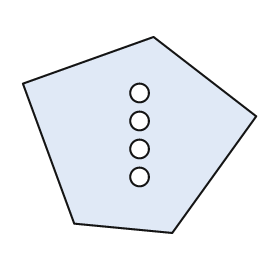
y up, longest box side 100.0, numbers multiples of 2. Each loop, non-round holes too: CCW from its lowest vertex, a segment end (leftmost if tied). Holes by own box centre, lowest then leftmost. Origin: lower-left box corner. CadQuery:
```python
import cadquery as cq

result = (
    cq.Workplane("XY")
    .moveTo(64.0, 0.0)
    .lineTo(100.0, 50.0)
    .lineTo(56.0, 84.0)
    .lineTo(0.0, 64.0)
    .lineTo(22.0, 4.0)
    .close()
    .moveTo(50.0, 24.0)
    .circle(4.0)
    .moveTo(50.0, 36.0)
    .circle(4.0)
    .moveTo(50.0, 48.0)
    .circle(4.0)
    .moveTo(50.0, 60.0)
    .circle(4.0)
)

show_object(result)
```